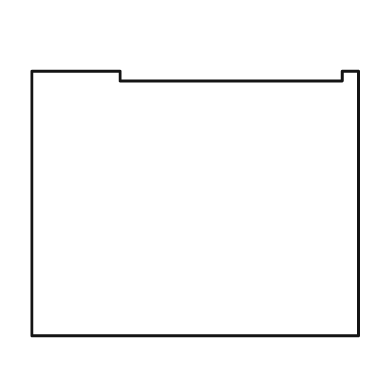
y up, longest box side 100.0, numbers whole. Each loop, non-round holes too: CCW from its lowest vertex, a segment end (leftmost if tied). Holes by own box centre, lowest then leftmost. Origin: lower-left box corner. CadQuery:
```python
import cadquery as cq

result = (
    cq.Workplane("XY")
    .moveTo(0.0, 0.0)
    .lineTo(100.0, 0.0)
    .lineTo(100.0, 81.0)
    .lineTo(95.0, 81.0)
    .lineTo(95.0, 78.0)
    .lineTo(27.0, 78.0)
    .lineTo(27.0, 81.0)
    .lineTo(0.0, 81.0)
    .close()
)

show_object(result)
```